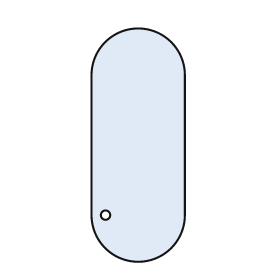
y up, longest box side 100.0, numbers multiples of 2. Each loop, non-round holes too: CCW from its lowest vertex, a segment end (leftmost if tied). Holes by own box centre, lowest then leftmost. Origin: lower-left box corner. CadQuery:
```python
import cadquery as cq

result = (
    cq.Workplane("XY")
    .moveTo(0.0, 20.0)
    .threePointArc((20.0, 0.0), (40.0, 20.0))
    .lineTo(40.0, 80.0)
    .threePointArc((20.0, 100.0), (0.0, 80.0))
    .close()
    .moveTo(6.0, 20.0)
    .circle(2.0)
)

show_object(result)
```